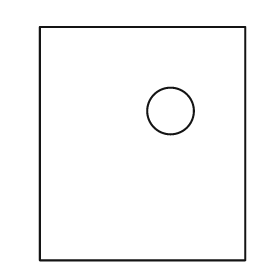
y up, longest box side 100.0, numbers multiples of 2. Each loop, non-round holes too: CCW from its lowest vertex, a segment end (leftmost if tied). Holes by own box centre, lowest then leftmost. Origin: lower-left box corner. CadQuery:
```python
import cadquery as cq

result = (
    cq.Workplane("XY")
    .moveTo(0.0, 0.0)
    .lineTo(88.0, 0.0)
    .lineTo(88.0, 100.0)
    .lineTo(0.0, 100.0)
    .close()
    .moveTo(56.0, 64.0)
    .circle(10.0)
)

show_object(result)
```